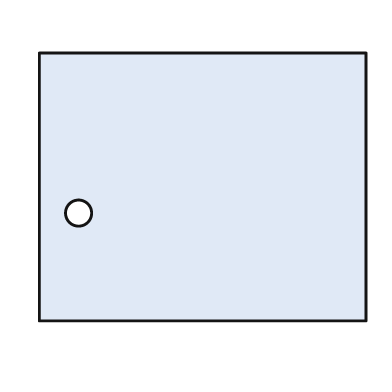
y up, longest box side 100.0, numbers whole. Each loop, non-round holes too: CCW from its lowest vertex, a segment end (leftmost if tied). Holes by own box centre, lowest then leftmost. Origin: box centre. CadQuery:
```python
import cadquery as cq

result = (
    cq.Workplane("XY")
    .moveTo(-50.0, -41.0)
    .lineTo(50.0, -41.0)
    .lineTo(50.0, 41.0)
    .lineTo(-50.0, 41.0)
    .close()
    .moveTo(-38.0, -8.0)
    .circle(4.0)
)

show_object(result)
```